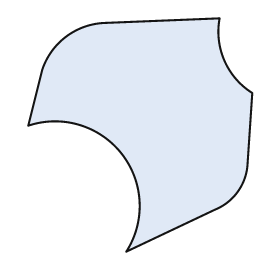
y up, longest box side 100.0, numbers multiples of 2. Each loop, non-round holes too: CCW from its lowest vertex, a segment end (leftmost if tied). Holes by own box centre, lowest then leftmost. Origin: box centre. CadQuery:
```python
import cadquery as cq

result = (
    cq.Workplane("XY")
    .moveTo(-6.0, -50.0)
    .lineTo(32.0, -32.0)
    .threePointArc((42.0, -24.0), (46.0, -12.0))
    .lineTo(48.0, 18.0)
    .threePointArc((36.0, 32.0), (34.0, 50.0))
    .lineTo(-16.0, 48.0)
    .threePointArc((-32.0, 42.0), (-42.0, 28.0))
    .lineTo(-48.0, 4.0)
    .threePointArc((-8.0, -8.0), (-6.0, -50.0))
    .close()
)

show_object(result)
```